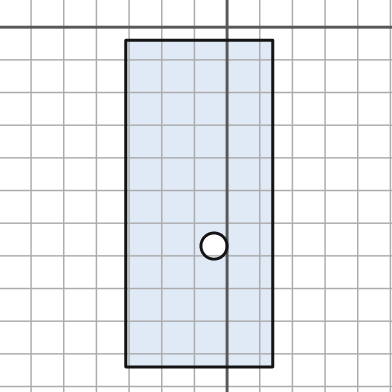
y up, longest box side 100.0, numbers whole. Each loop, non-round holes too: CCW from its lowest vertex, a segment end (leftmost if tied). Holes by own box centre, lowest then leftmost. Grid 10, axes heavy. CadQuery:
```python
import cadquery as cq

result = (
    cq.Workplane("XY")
    .moveTo(-31.0, -104.0)
    .lineTo(14.0, -104.0)
    .lineTo(14.0, -4.0)
    .lineTo(-31.0, -4.0)
    .close()
    .moveTo(-4.0, -67.0)
    .circle(4.0)
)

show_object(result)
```